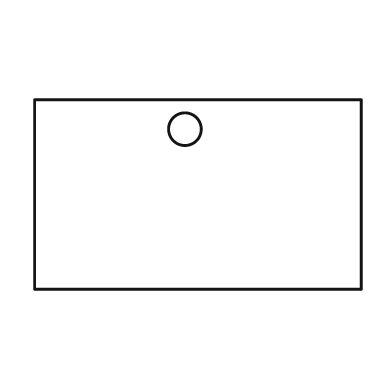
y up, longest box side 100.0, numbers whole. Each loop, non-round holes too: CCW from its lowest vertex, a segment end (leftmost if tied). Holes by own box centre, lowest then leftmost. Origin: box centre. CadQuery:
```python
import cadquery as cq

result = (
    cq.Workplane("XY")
    .moveTo(-50.0, -29.0)
    .lineTo(50.0, -29.0)
    .lineTo(50.0, 29.0)
    .lineTo(-50.0, 29.0)
    .close()
    .moveTo(-4.0, 20.0)
    .circle(5.0)
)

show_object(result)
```